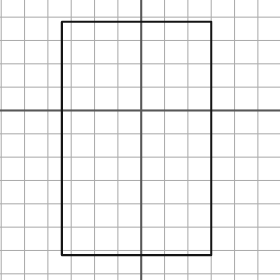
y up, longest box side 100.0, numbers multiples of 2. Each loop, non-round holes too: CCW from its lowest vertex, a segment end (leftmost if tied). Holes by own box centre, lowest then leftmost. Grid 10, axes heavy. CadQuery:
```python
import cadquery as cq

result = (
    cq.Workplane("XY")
    .moveTo(-34.0, -62.0)
    .lineTo(30.0, -62.0)
    .lineTo(30.0, 38.0)
    .lineTo(-34.0, 38.0)
    .close()
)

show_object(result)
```